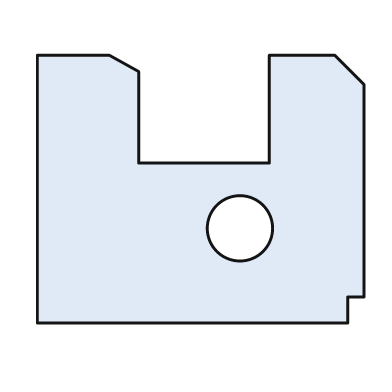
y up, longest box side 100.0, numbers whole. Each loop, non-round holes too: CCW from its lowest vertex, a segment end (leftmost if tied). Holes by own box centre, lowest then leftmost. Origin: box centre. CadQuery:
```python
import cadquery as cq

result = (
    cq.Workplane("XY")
    .moveTo(-50.0, -41.0)
    .lineTo(45.0, -41.0)
    .lineTo(45.0, -33.0)
    .lineTo(50.0, -33.0)
    .lineTo(50.0, 32.0)
    .lineTo(41.0, 41.0)
    .lineTo(21.0, 41.0)
    .lineTo(21.0, 8.0)
    .lineTo(-19.0, 8.0)
    .lineTo(-19.0, 36.0)
    .lineTo(-28.0, 41.0)
    .lineTo(-50.0, 41.0)
    .close()
    .moveTo(12.0, -12.0)
    .circle(10.0)
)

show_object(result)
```